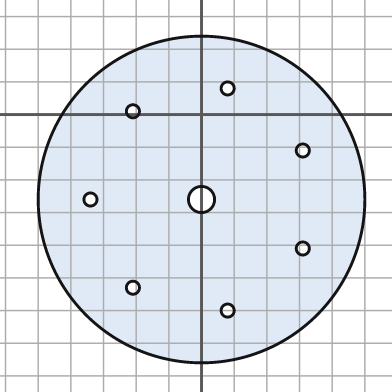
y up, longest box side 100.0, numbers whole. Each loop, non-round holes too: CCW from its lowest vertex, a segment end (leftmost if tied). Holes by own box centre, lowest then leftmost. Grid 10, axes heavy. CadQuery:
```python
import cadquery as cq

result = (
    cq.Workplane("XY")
    .moveTo(0.0, -26.0)
    .circle(50.0)
    .moveTo(8.0, -60.0)
    .circle(2.0)
    .moveTo(-21.0, -53.0)
    .circle(2.0)
    .moveTo(31.0, -41.0)
    .circle(2.0)
    .moveTo(-34.0, -26.0)
    .circle(2.0)
    .moveTo(0.0, -26.0)
    .circle(4.0)
    .moveTo(31.0, -11.0)
    .circle(2.0)
    .moveTo(-21.0, 1.0)
    .circle(2.0)
    .moveTo(8.0, 8.0)
    .circle(2.0)
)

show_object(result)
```